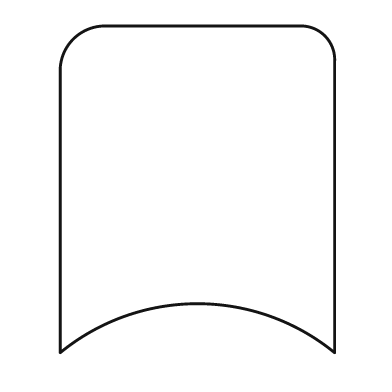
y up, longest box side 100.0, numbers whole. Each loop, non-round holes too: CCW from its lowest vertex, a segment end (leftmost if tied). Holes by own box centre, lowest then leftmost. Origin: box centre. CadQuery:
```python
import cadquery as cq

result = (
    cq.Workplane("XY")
    .moveTo(-42.0, -50.0)
    .threePointArc((0.0, -35.0), (42.0, -50.0))
    .lineTo(42.0, 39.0)
    .threePointArc((39.0, 47.0), (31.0, 50.0))
    .lineTo(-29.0, 50.0)
    .threePointArc((-38.0, 46.0), (-42.0, 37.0))
    .close()
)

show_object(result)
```